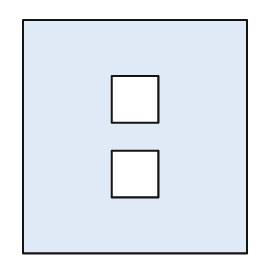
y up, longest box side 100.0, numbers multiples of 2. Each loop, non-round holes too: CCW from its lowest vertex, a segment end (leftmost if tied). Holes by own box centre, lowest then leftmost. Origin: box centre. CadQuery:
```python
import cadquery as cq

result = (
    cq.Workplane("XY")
    .moveTo(-48.0, -50.0)
    .lineTo(48.0, -50.0)
    .lineTo(48.0, 50.0)
    .lineTo(-48.0, 50.0)
    .close()
    .moveTo(-10.0, -26.0)
    .lineTo(10.0, -26.0)
    .lineTo(10.0, -6.0)
    .lineTo(-10.0, -6.0)
    .close()
    .moveTo(-10.0, 6.0)
    .lineTo(10.0, 6.0)
    .lineTo(10.0, 26.0)
    .lineTo(-10.0, 26.0)
    .close()
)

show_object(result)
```